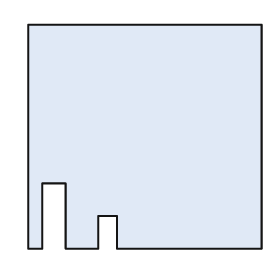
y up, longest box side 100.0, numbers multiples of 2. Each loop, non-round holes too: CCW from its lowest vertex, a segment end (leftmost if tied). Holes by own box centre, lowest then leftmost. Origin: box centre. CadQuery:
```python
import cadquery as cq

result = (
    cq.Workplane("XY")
    .moveTo(-50.0, -48.0)
    .lineTo(-44.0, -48.0)
    .lineTo(-44.0, -20.0)
    .lineTo(-34.0, -20.0)
    .lineTo(-34.0, -48.0)
    .lineTo(-20.0, -48.0)
    .lineTo(-20.0, -34.0)
    .lineTo(-12.0, -34.0)
    .lineTo(-12.0, -48.0)
    .lineTo(50.0, -48.0)
    .lineTo(50.0, 48.0)
    .lineTo(-50.0, 48.0)
    .close()
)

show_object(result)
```